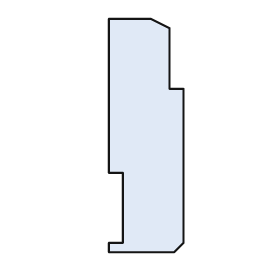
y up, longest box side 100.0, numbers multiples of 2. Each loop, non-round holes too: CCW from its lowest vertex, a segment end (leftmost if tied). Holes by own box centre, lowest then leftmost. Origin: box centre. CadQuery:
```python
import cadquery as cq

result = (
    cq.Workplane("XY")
    .moveTo(-16.0, -50.0)
    .lineTo(12.0, -50.0)
    .lineTo(16.0, -46.0)
    .lineTo(16.0, 20.0)
    .lineTo(10.0, 20.0)
    .lineTo(10.0, 46.0)
    .lineTo(2.0, 50.0)
    .lineTo(-16.0, 50.0)
    .lineTo(-16.0, -16.0)
    .lineTo(-10.0, -16.0)
    .lineTo(-10.0, -46.0)
    .lineTo(-16.0, -46.0)
    .close()
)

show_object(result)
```